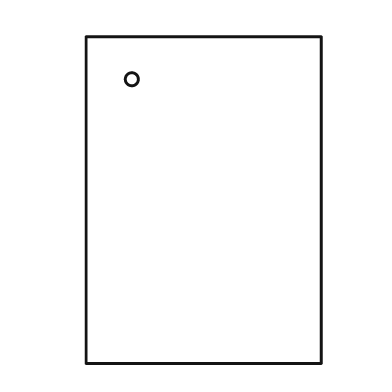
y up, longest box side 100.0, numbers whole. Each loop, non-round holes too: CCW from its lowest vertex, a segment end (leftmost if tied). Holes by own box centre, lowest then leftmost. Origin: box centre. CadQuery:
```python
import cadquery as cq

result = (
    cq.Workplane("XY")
    .moveTo(-36.0, -50.0)
    .lineTo(36.0, -50.0)
    .lineTo(36.0, 50.0)
    .lineTo(-36.0, 50.0)
    .close()
    .moveTo(-22.0, 37.0)
    .circle(2.0)
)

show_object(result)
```